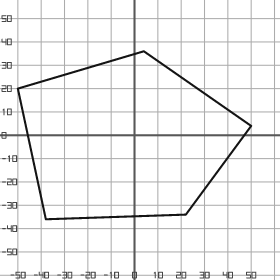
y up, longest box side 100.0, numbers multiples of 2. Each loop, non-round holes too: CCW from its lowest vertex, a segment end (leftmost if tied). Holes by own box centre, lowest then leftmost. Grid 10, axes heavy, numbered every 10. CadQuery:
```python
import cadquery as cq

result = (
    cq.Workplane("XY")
    .moveTo(-38.0, -36.0)
    .lineTo(22.0, -34.0)
    .lineTo(50.0, 4.0)
    .lineTo(4.0, 36.0)
    .lineTo(-50.0, 20.0)
    .close()
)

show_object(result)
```